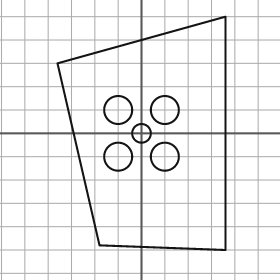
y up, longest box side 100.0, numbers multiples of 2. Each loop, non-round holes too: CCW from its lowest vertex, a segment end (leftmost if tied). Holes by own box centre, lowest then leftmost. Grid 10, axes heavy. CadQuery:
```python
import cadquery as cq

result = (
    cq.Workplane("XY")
    .moveTo(36.0, -50.0)
    .lineTo(36.0, 50.0)
    .lineTo(-36.0, 30.0)
    .lineTo(-18.0, -48.0)
    .close()
    .moveTo(-10.0, -10.0)
    .circle(6.0)
    .moveTo(10.0, -10.0)
    .circle(6.0)
    .moveTo(0.0, 0.0)
    .circle(4.0)
    .moveTo(-10.0, 10.0)
    .circle(6.0)
    .moveTo(10.0, 10.0)
    .circle(6.0)
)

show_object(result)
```